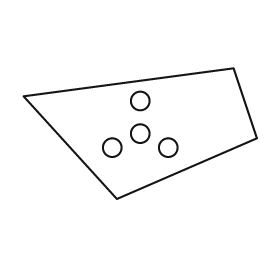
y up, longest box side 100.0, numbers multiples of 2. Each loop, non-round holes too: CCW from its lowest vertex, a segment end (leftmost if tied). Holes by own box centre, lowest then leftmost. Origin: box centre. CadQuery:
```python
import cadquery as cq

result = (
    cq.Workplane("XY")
    .moveTo(-10.0, -28.0)
    .lineTo(50.0, -2.0)
    .lineTo(40.0, 28.0)
    .lineTo(-50.0, 16.0)
    .close()
    .moveTo(-12.0, -6.0)
    .circle(4.0)
    .moveTo(12.0, -6.0)
    .circle(4.0)
    .moveTo(0.0, 0.0)
    .circle(4.0)
    .moveTo(0.0, 14.0)
    .circle(4.0)
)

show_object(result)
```